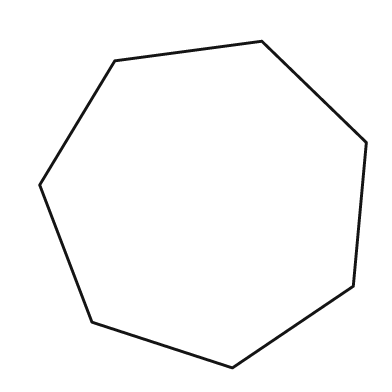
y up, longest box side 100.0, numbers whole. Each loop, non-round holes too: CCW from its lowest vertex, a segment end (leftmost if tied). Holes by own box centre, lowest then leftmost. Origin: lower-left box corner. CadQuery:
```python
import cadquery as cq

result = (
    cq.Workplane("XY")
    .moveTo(59.0, 0.0)
    .lineTo(96.0, 25.0)
    .lineTo(100.0, 69.0)
    .lineTo(68.0, 100.0)
    .lineTo(23.0, 94.0)
    .lineTo(0.0, 56.0)
    .lineTo(16.0, 14.0)
    .close()
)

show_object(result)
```